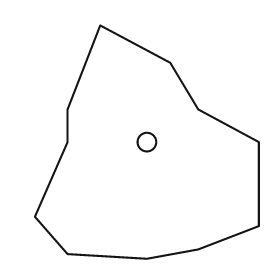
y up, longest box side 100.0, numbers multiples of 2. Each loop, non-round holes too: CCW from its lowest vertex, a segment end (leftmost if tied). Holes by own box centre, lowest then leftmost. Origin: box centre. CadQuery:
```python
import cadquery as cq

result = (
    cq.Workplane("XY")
    .moveTo(0.0, -50.0)
    .lineTo(22.0, -46.0)
    .lineTo(48.0, -36.0)
    .lineTo(48.0, 0.0)
    .lineTo(22.0, 14.0)
    .lineTo(10.0, 34.0)
    .lineTo(-20.0, 50.0)
    .lineTo(-34.0, 14.0)
    .lineTo(-34.0, 0.0)
    .lineTo(-48.0, -32.0)
    .lineTo(-34.0, -48.0)
    .close()
    .moveTo(0.0, 0.0)
    .circle(4.0)
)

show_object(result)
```